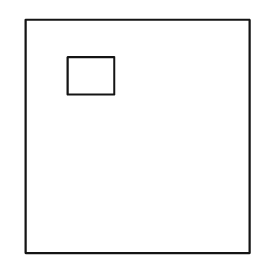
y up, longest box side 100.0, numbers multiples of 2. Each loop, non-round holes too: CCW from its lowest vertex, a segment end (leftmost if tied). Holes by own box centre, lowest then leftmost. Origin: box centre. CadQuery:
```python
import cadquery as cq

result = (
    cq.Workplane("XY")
    .moveTo(-48.0, -50.0)
    .lineTo(48.0, -50.0)
    .lineTo(48.0, 50.0)
    .lineTo(-48.0, 50.0)
    .close()
    .moveTo(-30.0, 18.0)
    .lineTo(-10.0, 18.0)
    .lineTo(-10.0, 34.0)
    .lineTo(-30.0, 34.0)
    .close()
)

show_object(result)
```